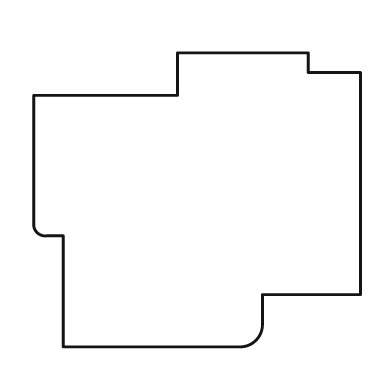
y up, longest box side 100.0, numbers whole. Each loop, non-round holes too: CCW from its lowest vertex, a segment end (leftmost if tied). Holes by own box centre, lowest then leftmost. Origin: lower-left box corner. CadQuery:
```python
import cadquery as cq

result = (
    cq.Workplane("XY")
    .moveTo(9.0, 0.0)
    .lineTo(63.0, 0.0)
    .threePointArc((68.0, 2.0), (70.0, 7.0))
    .lineTo(70.0, 16.0)
    .lineTo(100.0, 16.0)
    .lineTo(100.0, 84.0)
    .lineTo(84.0, 84.0)
    .lineTo(84.0, 90.0)
    .lineTo(44.0, 90.0)
    .lineTo(44.0, 77.0)
    .lineTo(0.0, 77.0)
    .lineTo(0.0, 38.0)
    .threePointArc((1.0, 35.0), (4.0, 34.0))
    .lineTo(9.0, 34.0)
    .close()
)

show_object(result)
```